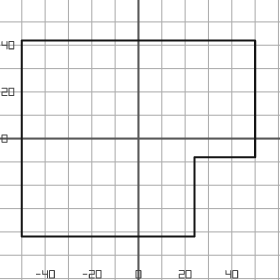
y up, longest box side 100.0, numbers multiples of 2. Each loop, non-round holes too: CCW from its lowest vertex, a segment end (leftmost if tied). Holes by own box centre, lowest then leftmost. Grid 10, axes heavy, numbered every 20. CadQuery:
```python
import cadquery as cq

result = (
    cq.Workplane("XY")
    .moveTo(-50.0, -42.0)
    .lineTo(24.0, -42.0)
    .lineTo(24.0, -8.0)
    .lineTo(50.0, -8.0)
    .lineTo(50.0, 42.0)
    .lineTo(-50.0, 42.0)
    .close()
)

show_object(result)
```